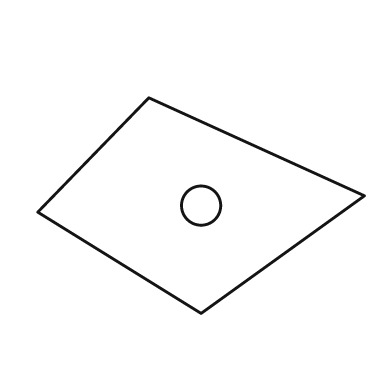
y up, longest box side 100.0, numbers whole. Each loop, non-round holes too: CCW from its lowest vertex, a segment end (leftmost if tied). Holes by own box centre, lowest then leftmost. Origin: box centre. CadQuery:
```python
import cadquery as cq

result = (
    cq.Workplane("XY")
    .moveTo(0.0, -33.0)
    .lineTo(50.0, 3.0)
    .lineTo(-16.0, 33.0)
    .lineTo(-50.0, -2.0)
    .close()
    .moveTo(0.0, 0.0)
    .circle(6.0)
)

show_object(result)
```